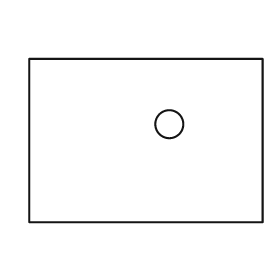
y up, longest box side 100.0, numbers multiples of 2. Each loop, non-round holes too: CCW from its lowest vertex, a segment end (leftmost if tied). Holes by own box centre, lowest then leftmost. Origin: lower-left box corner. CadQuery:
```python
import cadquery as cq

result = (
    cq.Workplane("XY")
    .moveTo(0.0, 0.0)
    .lineTo(100.0, 0.0)
    .lineTo(100.0, 70.0)
    .lineTo(0.0, 70.0)
    .close()
    .moveTo(60.0, 42.0)
    .circle(6.0)
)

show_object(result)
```